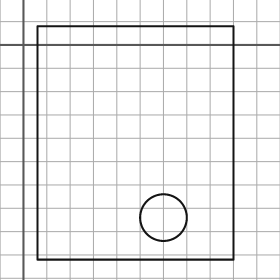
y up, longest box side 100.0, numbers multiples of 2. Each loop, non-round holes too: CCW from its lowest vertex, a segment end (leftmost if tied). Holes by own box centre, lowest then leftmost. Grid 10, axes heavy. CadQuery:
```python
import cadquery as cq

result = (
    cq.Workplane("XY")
    .moveTo(6.0, -92.0)
    .lineTo(90.0, -92.0)
    .lineTo(90.0, 8.0)
    .lineTo(6.0, 8.0)
    .close()
    .moveTo(60.0, -74.0)
    .circle(10.0)
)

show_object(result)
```